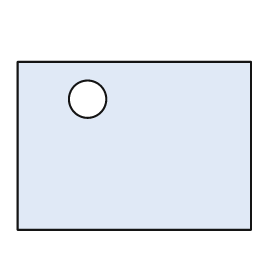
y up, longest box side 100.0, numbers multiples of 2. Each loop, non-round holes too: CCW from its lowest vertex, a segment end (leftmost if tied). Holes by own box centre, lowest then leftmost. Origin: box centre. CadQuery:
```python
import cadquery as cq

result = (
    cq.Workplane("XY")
    .moveTo(-50.0, -36.0)
    .lineTo(50.0, -36.0)
    .lineTo(50.0, 36.0)
    .lineTo(-50.0, 36.0)
    .close()
    .moveTo(-20.0, 20.0)
    .circle(8.0)
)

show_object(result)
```